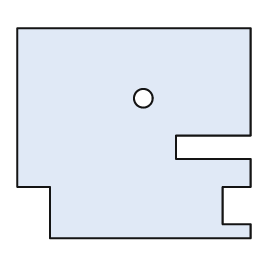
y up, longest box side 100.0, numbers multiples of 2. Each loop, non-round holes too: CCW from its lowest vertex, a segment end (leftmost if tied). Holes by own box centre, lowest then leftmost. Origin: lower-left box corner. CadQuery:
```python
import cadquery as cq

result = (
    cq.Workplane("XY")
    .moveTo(14.0, 0.0)
    .lineTo(100.0, 0.0)
    .lineTo(100.0, 6.0)
    .lineTo(88.0, 6.0)
    .lineTo(88.0, 22.0)
    .lineTo(100.0, 22.0)
    .lineTo(100.0, 34.0)
    .lineTo(68.0, 34.0)
    .lineTo(68.0, 44.0)
    .lineTo(100.0, 44.0)
    .lineTo(100.0, 90.0)
    .lineTo(0.0, 90.0)
    .lineTo(0.0, 22.0)
    .lineTo(14.0, 22.0)
    .close()
    .moveTo(54.0, 60.0)
    .circle(4.0)
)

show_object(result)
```